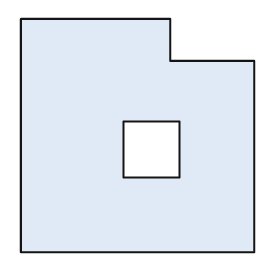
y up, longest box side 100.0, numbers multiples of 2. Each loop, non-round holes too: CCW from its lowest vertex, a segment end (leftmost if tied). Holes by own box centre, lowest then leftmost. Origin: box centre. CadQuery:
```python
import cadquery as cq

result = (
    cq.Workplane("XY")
    .moveTo(-50.0, -50.0)
    .lineTo(50.0, -50.0)
    .lineTo(50.0, 32.0)
    .lineTo(14.0, 32.0)
    .lineTo(14.0, 50.0)
    .lineTo(-50.0, 50.0)
    .close()
    .moveTo(-6.0, -18.0)
    .lineTo(18.0, -18.0)
    .lineTo(18.0, 6.0)
    .lineTo(-6.0, 6.0)
    .close()
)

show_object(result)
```